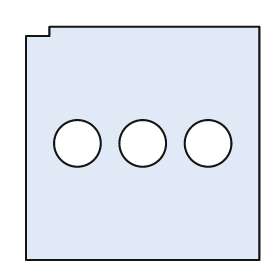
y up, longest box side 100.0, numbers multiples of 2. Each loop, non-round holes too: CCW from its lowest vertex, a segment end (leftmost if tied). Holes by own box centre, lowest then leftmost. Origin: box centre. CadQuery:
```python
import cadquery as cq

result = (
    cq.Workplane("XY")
    .moveTo(-50.0, -50.0)
    .lineTo(50.0, -50.0)
    .lineTo(50.0, 50.0)
    .lineTo(-40.0, 50.0)
    .lineTo(-40.0, 46.0)
    .lineTo(-50.0, 46.0)
    .close()
    .moveTo(-28.0, 0.0)
    .circle(10.0)
    .moveTo(0.0, 0.0)
    .circle(10.0)
    .moveTo(28.0, 0.0)
    .circle(10.0)
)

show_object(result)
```